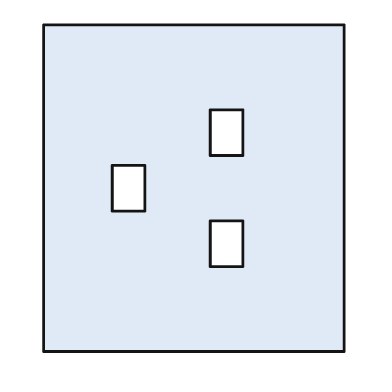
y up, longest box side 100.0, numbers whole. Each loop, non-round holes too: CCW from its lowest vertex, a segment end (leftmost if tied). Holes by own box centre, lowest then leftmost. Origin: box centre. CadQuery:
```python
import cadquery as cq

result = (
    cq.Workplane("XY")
    .moveTo(-46.0, -50.0)
    .lineTo(46.0, -50.0)
    .lineTo(46.0, 50.0)
    .lineTo(-46.0, 50.0)
    .close()
    .moveTo(5.0, -24.0)
    .lineTo(15.0, -24.0)
    .lineTo(15.0, -10.0)
    .lineTo(5.0, -10.0)
    .close()
    .moveTo(-25.0, -7.0)
    .lineTo(-15.0, -7.0)
    .lineTo(-15.0, 7.0)
    .lineTo(-25.0, 7.0)
    .close()
    .moveTo(5.0, 10.0)
    .lineTo(15.0, 10.0)
    .lineTo(15.0, 24.0)
    .lineTo(5.0, 24.0)
    .close()
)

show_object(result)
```